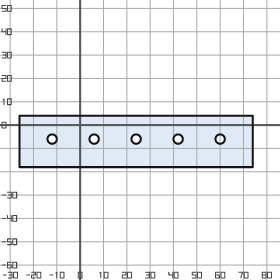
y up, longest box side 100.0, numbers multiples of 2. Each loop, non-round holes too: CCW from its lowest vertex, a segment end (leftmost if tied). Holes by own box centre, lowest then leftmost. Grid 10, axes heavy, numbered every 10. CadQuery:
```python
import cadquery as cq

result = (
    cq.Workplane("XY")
    .moveTo(-26.0, -18.0)
    .lineTo(74.0, -18.0)
    .lineTo(74.0, 4.0)
    .lineTo(-26.0, 4.0)
    .close()
    .moveTo(-12.0, -6.0)
    .circle(2.0)
    .moveTo(6.0, -6.0)
    .circle(2.0)
    .moveTo(24.0, -6.0)
    .circle(2.0)
    .moveTo(42.0, -6.0)
    .circle(2.0)
    .moveTo(60.0, -6.0)
    .circle(2.0)
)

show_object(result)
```